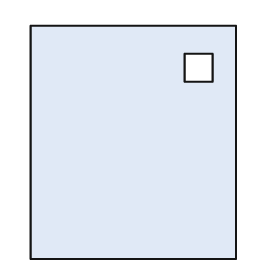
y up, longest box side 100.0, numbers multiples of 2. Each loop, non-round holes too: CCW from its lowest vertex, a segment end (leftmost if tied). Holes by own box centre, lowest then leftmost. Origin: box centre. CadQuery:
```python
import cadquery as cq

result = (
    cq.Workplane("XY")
    .moveTo(-44.0, -50.0)
    .lineTo(44.0, -50.0)
    .lineTo(44.0, 50.0)
    .lineTo(-44.0, 50.0)
    .close()
    .moveTo(22.0, 26.0)
    .lineTo(34.0, 26.0)
    .lineTo(34.0, 38.0)
    .lineTo(22.0, 38.0)
    .close()
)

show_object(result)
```